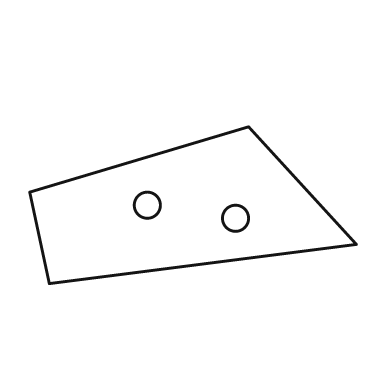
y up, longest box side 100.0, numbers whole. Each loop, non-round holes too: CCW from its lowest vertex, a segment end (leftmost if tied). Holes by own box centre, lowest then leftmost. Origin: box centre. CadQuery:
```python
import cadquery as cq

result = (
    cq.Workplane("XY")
    .moveTo(-44.0, -24.0)
    .lineTo(50.0, -12.0)
    .lineTo(17.0, 24.0)
    .lineTo(-50.0, 4.0)
    .close()
    .moveTo(13.0, -4.0)
    .circle(4.0)
    .moveTo(-14.0, 0.0)
    .circle(4.0)
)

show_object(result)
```